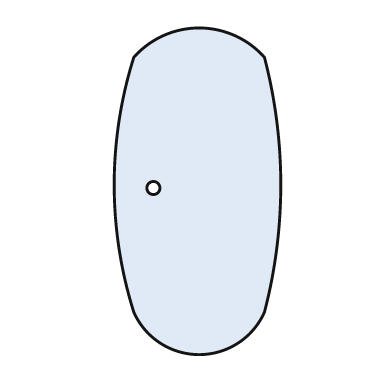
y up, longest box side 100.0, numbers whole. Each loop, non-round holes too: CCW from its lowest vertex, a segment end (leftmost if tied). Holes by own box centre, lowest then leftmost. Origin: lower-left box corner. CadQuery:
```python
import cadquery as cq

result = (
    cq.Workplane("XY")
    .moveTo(6.0, 13.0)
    .threePointArc((26.0, 0.0), (46.0, 13.0))
    .threePointArc((51.0, 52.0), (46.0, 91.0))
    .threePointArc((26.0, 100.0), (6.0, 91.0))
    .threePointArc((0.0, 52.0), (6.0, 13.0))
    .close()
    .moveTo(12.0, 51.0)
    .circle(2.0)
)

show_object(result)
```